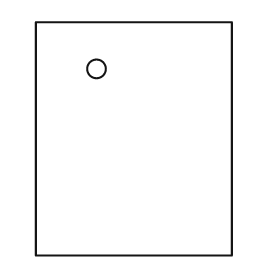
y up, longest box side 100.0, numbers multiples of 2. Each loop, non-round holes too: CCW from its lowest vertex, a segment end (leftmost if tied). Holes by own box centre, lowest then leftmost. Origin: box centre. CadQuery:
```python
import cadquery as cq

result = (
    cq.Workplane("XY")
    .moveTo(-42.0, -50.0)
    .lineTo(42.0, -50.0)
    .lineTo(42.0, 50.0)
    .lineTo(-42.0, 50.0)
    .close()
    .moveTo(-16.0, 30.0)
    .circle(4.0)
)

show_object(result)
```